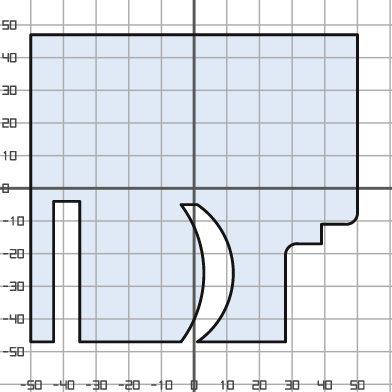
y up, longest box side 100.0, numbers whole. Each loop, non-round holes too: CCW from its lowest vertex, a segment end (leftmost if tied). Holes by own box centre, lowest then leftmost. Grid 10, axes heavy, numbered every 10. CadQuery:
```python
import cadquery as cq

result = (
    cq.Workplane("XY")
    .moveTo(-50.0, -47.0)
    .lineTo(-43.0, -47.0)
    .lineTo(-43.0, -4.0)
    .lineTo(-35.0, -4.0)
    .lineTo(-35.0, -47.0)
    .lineTo(-4.0, -47.0)
    .threePointArc((3.0, -26.0), (-4.0, -5.0))
    .lineTo(1.0, -5.0)
    .threePointArc((12.0, -26.0), (1.0, -47.0))
    .lineTo(28.0, -47.0)
    .lineTo(28.0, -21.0)
    .threePointArc((29.0, -18.0), (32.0, -17.0))
    .lineTo(39.0, -17.0)
    .lineTo(39.0, -11.0)
    .lineTo(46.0, -11.0)
    .threePointArc((49.0, -10.0), (50.0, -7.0))
    .lineTo(50.0, 47.0)
    .lineTo(-50.0, 47.0)
    .close()
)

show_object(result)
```